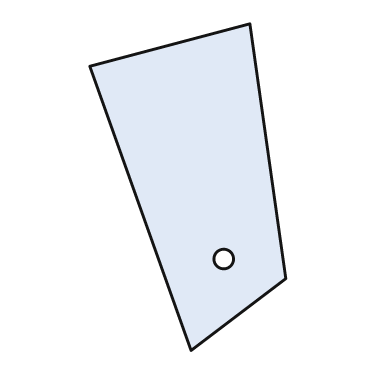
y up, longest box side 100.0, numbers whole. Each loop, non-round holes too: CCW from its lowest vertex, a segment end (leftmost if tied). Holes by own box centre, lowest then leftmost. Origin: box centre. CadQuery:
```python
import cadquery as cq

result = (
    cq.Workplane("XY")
    .moveTo(1.0, -50.0)
    .lineTo(30.0, -28.0)
    .lineTo(19.0, 50.0)
    .lineTo(-30.0, 37.0)
    .close()
    .moveTo(11.0, -22.0)
    .circle(3.0)
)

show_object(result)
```